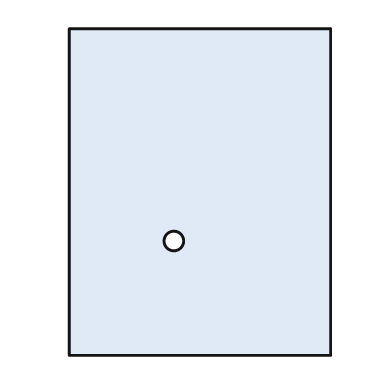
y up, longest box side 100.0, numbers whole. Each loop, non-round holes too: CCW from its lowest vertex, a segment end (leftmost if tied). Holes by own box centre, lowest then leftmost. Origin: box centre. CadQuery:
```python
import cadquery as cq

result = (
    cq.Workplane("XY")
    .moveTo(-40.0, -50.0)
    .lineTo(40.0, -50.0)
    .lineTo(40.0, 50.0)
    .lineTo(-40.0, 50.0)
    .close()
    .moveTo(-8.0, -15.0)
    .circle(3.0)
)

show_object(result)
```